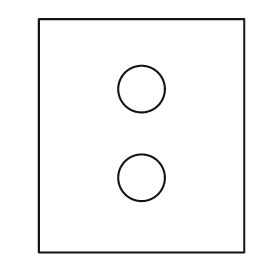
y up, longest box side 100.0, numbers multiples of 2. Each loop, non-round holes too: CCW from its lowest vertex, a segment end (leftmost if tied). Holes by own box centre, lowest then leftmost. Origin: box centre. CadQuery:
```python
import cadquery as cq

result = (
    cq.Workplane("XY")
    .moveTo(-44.0, -50.0)
    .lineTo(44.0, -50.0)
    .lineTo(44.0, 50.0)
    .lineTo(-44.0, 50.0)
    .close()
    .moveTo(0.0, -18.0)
    .circle(10.0)
    .moveTo(0.0, 20.0)
    .circle(10.0)
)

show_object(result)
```